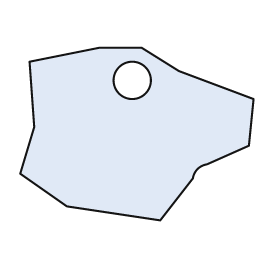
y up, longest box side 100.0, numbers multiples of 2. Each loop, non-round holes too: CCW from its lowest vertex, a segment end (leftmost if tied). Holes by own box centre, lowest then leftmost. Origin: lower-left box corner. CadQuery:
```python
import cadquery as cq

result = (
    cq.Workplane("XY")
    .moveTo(60.0, 0.0)
    .lineTo(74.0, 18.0)
    .threePointArc((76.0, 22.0), (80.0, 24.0))
    .lineTo(98.0, 32.0)
    .lineTo(100.0, 52.0)
    .lineTo(68.0, 64.0)
    .lineTo(52.0, 74.0)
    .lineTo(34.0, 74.0)
    .lineTo(4.0, 68.0)
    .lineTo(6.0, 40.0)
    .lineTo(0.0, 20.0)
    .lineTo(20.0, 6.0)
    .close()
    .moveTo(48.0, 60.0)
    .circle(8.0)
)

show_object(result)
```